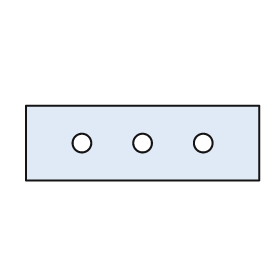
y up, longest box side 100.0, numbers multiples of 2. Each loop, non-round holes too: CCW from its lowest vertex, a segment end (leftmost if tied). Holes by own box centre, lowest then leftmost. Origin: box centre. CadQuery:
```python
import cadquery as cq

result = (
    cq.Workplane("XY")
    .moveTo(-50.0, -16.0)
    .lineTo(50.0, -16.0)
    .lineTo(50.0, 16.0)
    .lineTo(-50.0, 16.0)
    .close()
    .moveTo(-26.0, 0.0)
    .circle(4.0)
    .moveTo(0.0, 0.0)
    .circle(4.0)
    .moveTo(26.0, 0.0)
    .circle(4.0)
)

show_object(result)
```